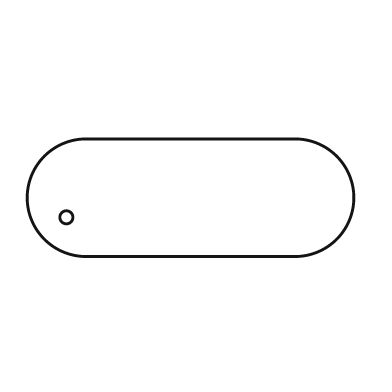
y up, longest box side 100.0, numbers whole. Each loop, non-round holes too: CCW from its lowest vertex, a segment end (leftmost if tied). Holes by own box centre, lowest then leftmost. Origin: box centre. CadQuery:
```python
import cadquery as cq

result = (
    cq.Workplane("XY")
    .moveTo(-32.0, -18.0)
    .lineTo(32.0, -18.0)
    .threePointArc((50.0, 0.0), (32.0, 18.0))
    .lineTo(-32.0, 18.0)
    .threePointArc((-50.0, 0.0), (-32.0, -18.0))
    .close()
    .moveTo(-38.0, -6.0)
    .circle(2.0)
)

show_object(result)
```